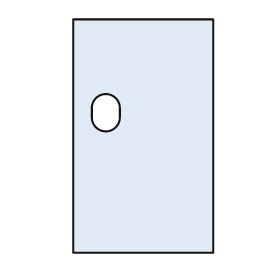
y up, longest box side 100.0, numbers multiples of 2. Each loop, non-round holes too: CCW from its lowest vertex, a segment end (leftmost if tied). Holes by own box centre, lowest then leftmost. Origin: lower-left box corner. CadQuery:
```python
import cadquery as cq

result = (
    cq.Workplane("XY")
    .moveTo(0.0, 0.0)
    .lineTo(60.0, 0.0)
    .lineTo(60.0, 100.0)
    .lineTo(0.0, 100.0)
    .close()
    .moveTo(8.0, 58.0)
    .threePointArc((14.0, 52.0), (20.0, 58.0))
    .lineTo(20.0, 62.0)
    .threePointArc((14.0, 68.0), (8.0, 62.0))
    .close()
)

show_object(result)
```